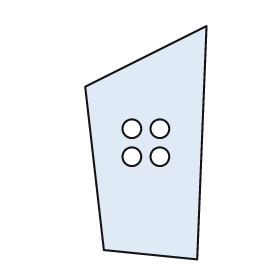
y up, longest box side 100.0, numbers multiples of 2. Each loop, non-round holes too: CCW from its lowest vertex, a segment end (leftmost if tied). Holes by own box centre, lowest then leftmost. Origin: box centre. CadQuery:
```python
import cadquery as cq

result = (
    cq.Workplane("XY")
    .moveTo(22.0, -50.0)
    .lineTo(26.0, 50.0)
    .lineTo(-26.0, 24.0)
    .lineTo(-18.0, -46.0)
    .close()
    .moveTo(-6.0, -6.0)
    .circle(4.0)
    .moveTo(6.0, -6.0)
    .circle(4.0)
    .moveTo(-6.0, 6.0)
    .circle(4.0)
    .moveTo(6.0, 6.0)
    .circle(4.0)
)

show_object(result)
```